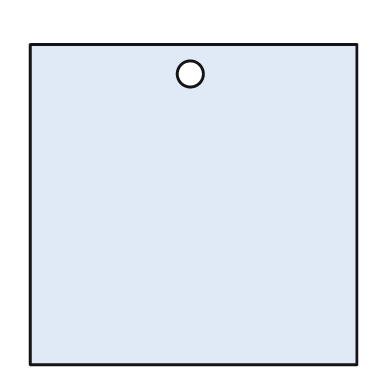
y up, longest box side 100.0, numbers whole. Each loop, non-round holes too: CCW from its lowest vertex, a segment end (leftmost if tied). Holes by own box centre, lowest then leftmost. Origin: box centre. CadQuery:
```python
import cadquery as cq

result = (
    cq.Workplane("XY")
    .moveTo(-50.0, -49.0)
    .lineTo(50.0, -49.0)
    .lineTo(50.0, 49.0)
    .lineTo(-50.0, 49.0)
    .close()
    .moveTo(-1.0, 40.0)
    .circle(4.0)
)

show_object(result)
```